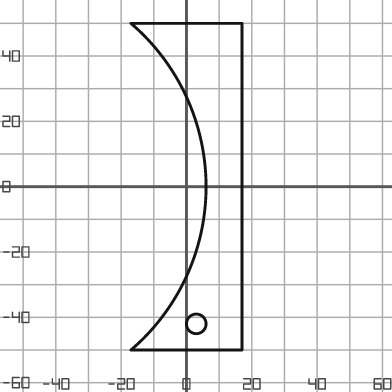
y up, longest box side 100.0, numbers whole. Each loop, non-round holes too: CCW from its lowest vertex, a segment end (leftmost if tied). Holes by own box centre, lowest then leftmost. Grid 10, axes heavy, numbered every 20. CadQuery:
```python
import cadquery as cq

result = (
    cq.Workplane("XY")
    .moveTo(-17.0, -50.0)
    .lineTo(17.0, -50.0)
    .lineTo(17.0, 50.0)
    .lineTo(-17.0, 50.0)
    .threePointArc((6.0, 0.0), (-17.0, -50.0))
    .close()
    .moveTo(3.0, -42.0)
    .circle(3.0)
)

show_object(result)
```